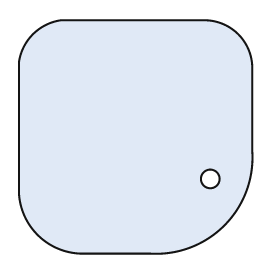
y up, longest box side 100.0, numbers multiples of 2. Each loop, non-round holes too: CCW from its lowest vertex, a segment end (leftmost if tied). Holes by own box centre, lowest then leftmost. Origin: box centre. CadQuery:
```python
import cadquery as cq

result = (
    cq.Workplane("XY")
    .moveTo(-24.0, -50.0)
    .lineTo(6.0, -50.0)
    .threePointArc((38.0, -38.0), (50.0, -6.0))
    .lineTo(50.0, 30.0)
    .threePointArc((44.0, 44.0), (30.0, 50.0))
    .lineTo(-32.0, 50.0)
    .threePointArc((-44.0, 44.0), (-50.0, 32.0))
    .lineTo(-50.0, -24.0)
    .threePointArc((-42.0, -42.0), (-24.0, -50.0))
    .close()
    .moveTo(32.0, -18.0)
    .circle(4.0)
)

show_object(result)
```